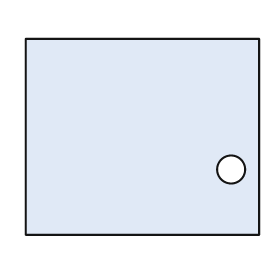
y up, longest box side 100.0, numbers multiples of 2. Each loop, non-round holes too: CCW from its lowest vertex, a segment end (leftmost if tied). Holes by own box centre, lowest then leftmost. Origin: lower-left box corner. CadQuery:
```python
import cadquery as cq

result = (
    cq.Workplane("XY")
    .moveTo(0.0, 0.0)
    .lineTo(100.0, 0.0)
    .lineTo(100.0, 84.0)
    .lineTo(0.0, 84.0)
    .close()
    .moveTo(88.0, 28.0)
    .circle(6.0)
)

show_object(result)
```